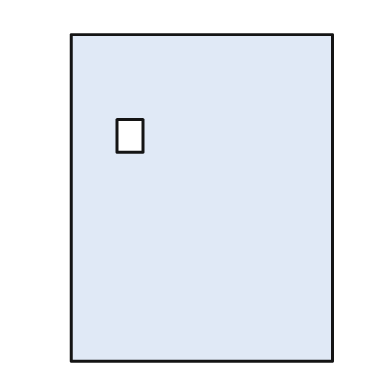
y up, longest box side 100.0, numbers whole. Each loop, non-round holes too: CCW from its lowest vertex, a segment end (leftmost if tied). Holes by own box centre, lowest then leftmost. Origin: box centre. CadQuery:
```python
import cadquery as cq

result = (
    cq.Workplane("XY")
    .moveTo(-40.0, -50.0)
    .lineTo(40.0, -50.0)
    .lineTo(40.0, 50.0)
    .lineTo(-40.0, 50.0)
    .close()
    .moveTo(-26.0, 14.0)
    .lineTo(-18.0, 14.0)
    .lineTo(-18.0, 24.0)
    .lineTo(-26.0, 24.0)
    .close()
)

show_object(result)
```